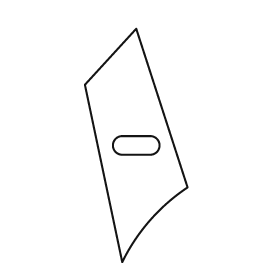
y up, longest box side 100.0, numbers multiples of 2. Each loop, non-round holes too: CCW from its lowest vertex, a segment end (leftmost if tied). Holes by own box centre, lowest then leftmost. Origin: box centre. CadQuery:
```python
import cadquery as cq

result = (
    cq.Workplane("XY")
    .moveTo(-6.0, -50.0)
    .threePointArc((6.0, -32.0), (22.0, -18.0))
    .lineTo(0.0, 50.0)
    .lineTo(-22.0, 26.0)
    .close()
    .moveTo(-6.0, -4.0)
    .lineTo(6.0, -4.0)
    .threePointArc((10.0, 0.0), (6.0, 4.0))
    .lineTo(-6.0, 4.0)
    .threePointArc((-10.0, 0.0), (-6.0, -4.0))
    .close()
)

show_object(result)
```